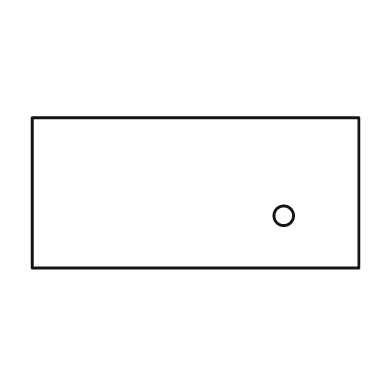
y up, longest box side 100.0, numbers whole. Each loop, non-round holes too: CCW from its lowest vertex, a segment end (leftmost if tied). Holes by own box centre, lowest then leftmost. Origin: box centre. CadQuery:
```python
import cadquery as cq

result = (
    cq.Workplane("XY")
    .moveTo(-50.0, -23.0)
    .lineTo(50.0, -23.0)
    .lineTo(50.0, 23.0)
    .lineTo(-50.0, 23.0)
    .close()
    .moveTo(27.0, -7.0)
    .circle(3.0)
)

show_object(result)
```